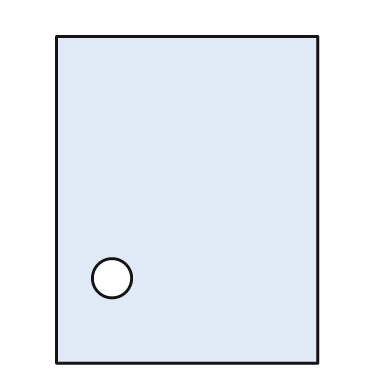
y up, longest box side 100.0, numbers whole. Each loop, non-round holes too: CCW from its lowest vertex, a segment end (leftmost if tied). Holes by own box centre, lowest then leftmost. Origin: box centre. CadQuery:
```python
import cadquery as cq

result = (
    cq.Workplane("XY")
    .moveTo(-40.0, -50.0)
    .lineTo(40.0, -50.0)
    .lineTo(40.0, 50.0)
    .lineTo(-40.0, 50.0)
    .close()
    .moveTo(-23.0, -24.0)
    .circle(6.0)
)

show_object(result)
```